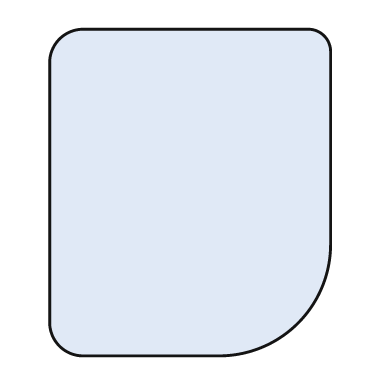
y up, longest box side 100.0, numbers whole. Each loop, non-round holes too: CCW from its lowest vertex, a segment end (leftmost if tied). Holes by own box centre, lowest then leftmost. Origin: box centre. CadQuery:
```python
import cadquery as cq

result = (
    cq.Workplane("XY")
    .moveTo(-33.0, -50.0)
    .lineTo(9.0, -50.0)
    .threePointArc((33.0, -40.0), (43.0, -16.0))
    .lineTo(43.0, 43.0)
    .threePointArc((41.0, 48.0), (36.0, 50.0))
    .lineTo(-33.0, 50.0)
    .threePointArc((-40.0, 47.0), (-43.0, 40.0))
    .lineTo(-43.0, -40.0)
    .threePointArc((-40.0, -47.0), (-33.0, -50.0))
    .close()
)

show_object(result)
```